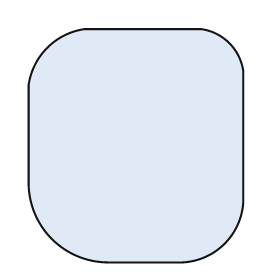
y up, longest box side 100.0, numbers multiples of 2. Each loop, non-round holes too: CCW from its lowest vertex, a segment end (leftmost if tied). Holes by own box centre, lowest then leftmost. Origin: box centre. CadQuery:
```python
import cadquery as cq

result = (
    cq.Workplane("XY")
    .moveTo(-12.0, -50.0)
    .lineTo(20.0, -50.0)
    .threePointArc((38.0, -42.0), (46.0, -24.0))
    .lineTo(46.0, 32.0)
    .threePointArc((40.0, 44.0), (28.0, 50.0))
    .lineTo(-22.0, 50.0)
    .threePointArc((-38.0, 42.0), (-46.0, 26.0))
    .lineTo(-46.0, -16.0)
    .threePointArc((-36.0, -40.0), (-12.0, -50.0))
    .close()
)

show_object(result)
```